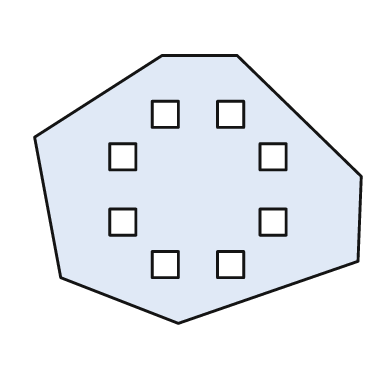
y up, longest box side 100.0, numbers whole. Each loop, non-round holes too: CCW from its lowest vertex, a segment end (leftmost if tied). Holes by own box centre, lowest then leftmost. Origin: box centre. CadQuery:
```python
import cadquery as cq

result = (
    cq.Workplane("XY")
    .moveTo(-6.0, -41.0)
    .lineTo(49.0, -22.0)
    .lineTo(50.0, 4.0)
    .lineTo(12.0, 41.0)
    .lineTo(-11.0, 41.0)
    .lineTo(-50.0, 16.0)
    .lineTo(-42.0, -27.0)
    .close()
    .moveTo(-14.0, -27.0)
    .lineTo(-6.0, -27.0)
    .lineTo(-6.0, -19.0)
    .lineTo(-14.0, -19.0)
    .close()
    .moveTo(6.0, -27.0)
    .lineTo(14.0, -27.0)
    .lineTo(14.0, -19.0)
    .lineTo(6.0, -19.0)
    .close()
    .moveTo(-27.0, -14.0)
    .lineTo(-19.0, -14.0)
    .lineTo(-19.0, -6.0)
    .lineTo(-27.0, -6.0)
    .close()
    .moveTo(19.0, -14.0)
    .lineTo(27.0, -14.0)
    .lineTo(27.0, -6.0)
    .lineTo(19.0, -6.0)
    .close()
    .moveTo(-27.0, 6.0)
    .lineTo(-19.0, 6.0)
    .lineTo(-19.0, 14.0)
    .lineTo(-27.0, 14.0)
    .close()
    .moveTo(19.0, 6.0)
    .lineTo(27.0, 6.0)
    .lineTo(27.0, 14.0)
    .lineTo(19.0, 14.0)
    .close()
    .moveTo(-14.0, 19.0)
    .lineTo(-6.0, 19.0)
    .lineTo(-6.0, 27.0)
    .lineTo(-14.0, 27.0)
    .close()
    .moveTo(6.0, 19.0)
    .lineTo(14.0, 19.0)
    .lineTo(14.0, 27.0)
    .lineTo(6.0, 27.0)
    .close()
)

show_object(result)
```